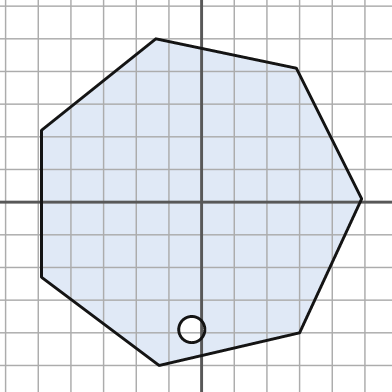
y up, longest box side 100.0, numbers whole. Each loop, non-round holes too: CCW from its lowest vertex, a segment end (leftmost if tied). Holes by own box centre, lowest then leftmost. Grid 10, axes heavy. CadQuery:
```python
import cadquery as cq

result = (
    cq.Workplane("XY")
    .moveTo(-13.0, -50.0)
    .lineTo(30.0, -40.0)
    .lineTo(49.0, 1.0)
    .lineTo(29.0, 41.0)
    .lineTo(-14.0, 50.0)
    .lineTo(-49.0, 22.0)
    .lineTo(-49.0, -23.0)
    .close()
    .moveTo(-3.0, -39.0)
    .circle(4.0)
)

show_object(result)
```